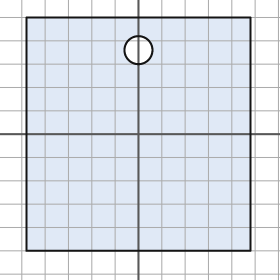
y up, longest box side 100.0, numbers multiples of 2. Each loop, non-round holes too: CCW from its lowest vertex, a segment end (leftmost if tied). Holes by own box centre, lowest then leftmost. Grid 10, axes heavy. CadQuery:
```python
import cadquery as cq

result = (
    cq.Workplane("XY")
    .moveTo(-48.0, -50.0)
    .lineTo(48.0, -50.0)
    .lineTo(48.0, 50.0)
    .lineTo(-48.0, 50.0)
    .close()
    .moveTo(0.0, 36.0)
    .circle(6.0)
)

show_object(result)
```